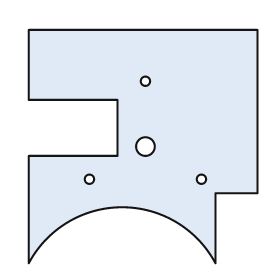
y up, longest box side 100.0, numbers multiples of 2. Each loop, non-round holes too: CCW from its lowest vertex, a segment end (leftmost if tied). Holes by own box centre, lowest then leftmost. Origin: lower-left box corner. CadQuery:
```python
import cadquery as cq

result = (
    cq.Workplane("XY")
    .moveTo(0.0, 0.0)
    .threePointArc((40.0, 24.0), (80.0, 0.0))
    .lineTo(80.0, 30.0)
    .lineTo(98.0, 30.0)
    .lineTo(98.0, 100.0)
    .lineTo(0.0, 100.0)
    .lineTo(0.0, 70.0)
    .lineTo(38.0, 70.0)
    .lineTo(38.0, 46.0)
    .lineTo(0.0, 46.0)
    .close()
    .moveTo(26.0, 36.0)
    .circle(2.0)
    .moveTo(74.0, 36.0)
    .circle(2.0)
    .moveTo(50.0, 50.0)
    .circle(4.0)
    .moveTo(50.0, 78.0)
    .circle(2.0)
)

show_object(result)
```